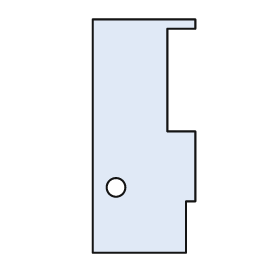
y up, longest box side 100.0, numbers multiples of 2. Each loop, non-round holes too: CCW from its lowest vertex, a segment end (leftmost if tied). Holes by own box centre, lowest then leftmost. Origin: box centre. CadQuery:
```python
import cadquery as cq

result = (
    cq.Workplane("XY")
    .moveTo(-22.0, -50.0)
    .lineTo(18.0, -50.0)
    .lineTo(18.0, -28.0)
    .lineTo(22.0, -28.0)
    .lineTo(22.0, 2.0)
    .lineTo(10.0, 2.0)
    .lineTo(10.0, 46.0)
    .lineTo(22.0, 46.0)
    .lineTo(22.0, 50.0)
    .lineTo(-22.0, 50.0)
    .close()
    .moveTo(-12.0, -22.0)
    .circle(4.0)
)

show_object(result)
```